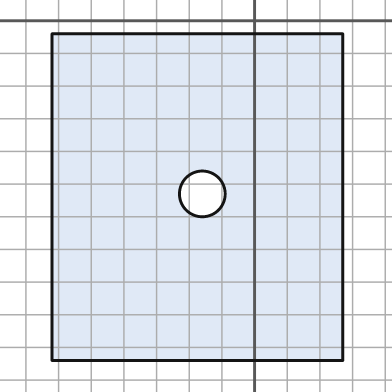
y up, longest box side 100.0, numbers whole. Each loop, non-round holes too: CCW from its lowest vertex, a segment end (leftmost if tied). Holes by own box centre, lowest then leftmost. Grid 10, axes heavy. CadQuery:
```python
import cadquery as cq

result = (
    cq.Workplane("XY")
    .moveTo(-62.0, -104.0)
    .lineTo(27.0, -104.0)
    .lineTo(27.0, -4.0)
    .lineTo(-62.0, -4.0)
    .close()
    .moveTo(-16.0, -53.0)
    .circle(7.0)
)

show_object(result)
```